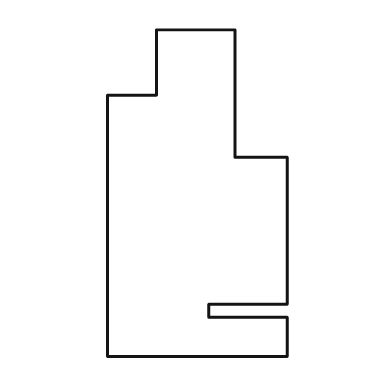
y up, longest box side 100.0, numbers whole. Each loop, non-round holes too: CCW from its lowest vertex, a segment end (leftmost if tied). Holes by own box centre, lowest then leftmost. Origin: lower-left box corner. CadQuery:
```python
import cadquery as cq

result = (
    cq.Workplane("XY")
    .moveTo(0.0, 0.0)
    .lineTo(55.0, 0.0)
    .lineTo(55.0, 12.0)
    .lineTo(31.0, 12.0)
    .lineTo(31.0, 16.0)
    .lineTo(55.0, 16.0)
    .lineTo(55.0, 61.0)
    .lineTo(39.0, 61.0)
    .lineTo(39.0, 100.0)
    .lineTo(15.0, 100.0)
    .lineTo(15.0, 80.0)
    .lineTo(0.0, 80.0)
    .close()
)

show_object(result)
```